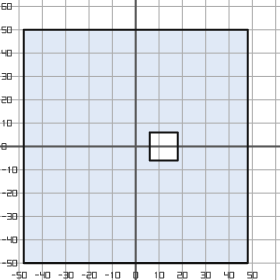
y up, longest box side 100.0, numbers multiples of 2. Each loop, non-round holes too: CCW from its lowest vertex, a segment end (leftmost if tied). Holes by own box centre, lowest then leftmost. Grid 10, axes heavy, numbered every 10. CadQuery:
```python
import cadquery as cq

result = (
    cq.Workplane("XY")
    .moveTo(-48.0, -50.0)
    .lineTo(48.0, -50.0)
    .lineTo(48.0, 50.0)
    .lineTo(-48.0, 50.0)
    .close()
    .moveTo(6.0, -6.0)
    .lineTo(18.0, -6.0)
    .lineTo(18.0, 6.0)
    .lineTo(6.0, 6.0)
    .close()
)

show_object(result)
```